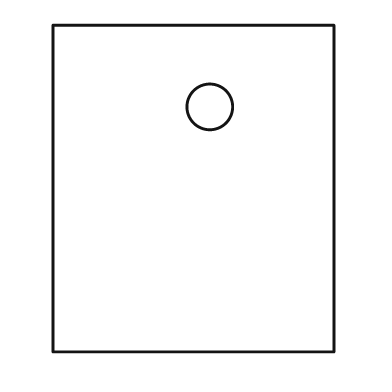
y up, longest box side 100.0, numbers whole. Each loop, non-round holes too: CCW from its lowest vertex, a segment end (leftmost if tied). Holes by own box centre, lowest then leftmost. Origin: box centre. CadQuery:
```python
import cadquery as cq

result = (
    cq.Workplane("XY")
    .moveTo(-43.0, -50.0)
    .lineTo(43.0, -50.0)
    .lineTo(43.0, 50.0)
    .lineTo(-43.0, 50.0)
    .close()
    .moveTo(5.0, 25.0)
    .circle(7.0)
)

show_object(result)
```